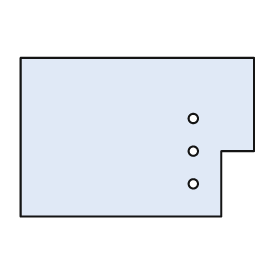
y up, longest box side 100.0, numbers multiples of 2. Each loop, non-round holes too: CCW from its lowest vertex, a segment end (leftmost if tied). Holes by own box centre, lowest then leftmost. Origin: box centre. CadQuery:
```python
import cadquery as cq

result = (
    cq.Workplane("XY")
    .moveTo(-50.0, -34.0)
    .lineTo(36.0, -34.0)
    .lineTo(36.0, -6.0)
    .lineTo(50.0, -6.0)
    .lineTo(50.0, 34.0)
    .lineTo(-50.0, 34.0)
    .close()
    .moveTo(24.0, -20.0)
    .circle(2.0)
    .moveTo(24.0, -6.0)
    .circle(2.0)
    .moveTo(24.0, 8.0)
    .circle(2.0)
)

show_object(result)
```